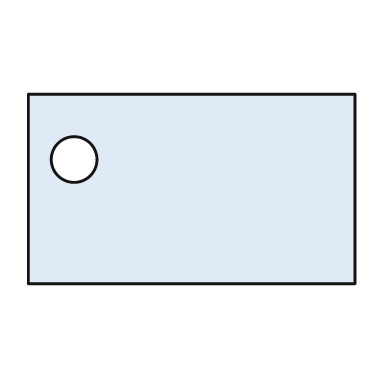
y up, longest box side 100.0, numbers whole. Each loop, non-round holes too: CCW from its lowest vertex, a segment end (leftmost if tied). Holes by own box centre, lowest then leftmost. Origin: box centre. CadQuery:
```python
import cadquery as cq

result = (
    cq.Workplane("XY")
    .moveTo(-50.0, -29.0)
    .lineTo(50.0, -29.0)
    .lineTo(50.0, 29.0)
    .lineTo(-50.0, 29.0)
    .close()
    .moveTo(-36.0, 9.0)
    .circle(7.0)
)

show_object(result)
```